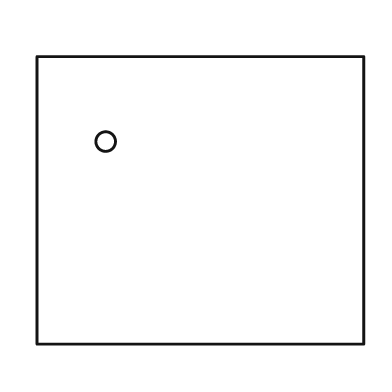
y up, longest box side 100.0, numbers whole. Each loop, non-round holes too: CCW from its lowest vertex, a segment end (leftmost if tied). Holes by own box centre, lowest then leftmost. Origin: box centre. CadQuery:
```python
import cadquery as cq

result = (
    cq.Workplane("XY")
    .moveTo(-50.0, -44.0)
    .lineTo(50.0, -44.0)
    .lineTo(50.0, 44.0)
    .lineTo(-50.0, 44.0)
    .close()
    .moveTo(-29.0, 18.0)
    .circle(3.0)
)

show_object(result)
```